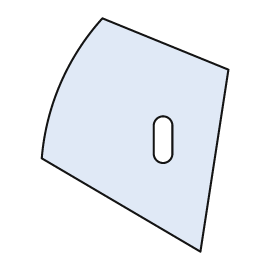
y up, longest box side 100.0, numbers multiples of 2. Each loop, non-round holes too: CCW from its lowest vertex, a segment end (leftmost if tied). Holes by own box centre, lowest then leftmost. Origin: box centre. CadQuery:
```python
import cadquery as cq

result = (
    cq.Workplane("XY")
    .moveTo(28.0, -50.0)
    .lineTo(40.0, 28.0)
    .lineTo(-14.0, 50.0)
    .threePointArc((-32.0, 22.0), (-40.0, -10.0))
    .close()
    .moveTo(8.0, -8.0)
    .threePointArc((12.0, -12.0), (16.0, -8.0))
    .lineTo(16.0, 4.0)
    .threePointArc((12.0, 8.0), (8.0, 4.0))
    .close()
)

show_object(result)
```